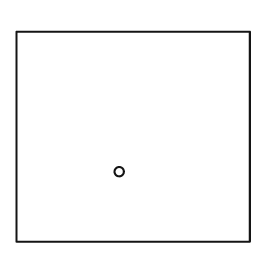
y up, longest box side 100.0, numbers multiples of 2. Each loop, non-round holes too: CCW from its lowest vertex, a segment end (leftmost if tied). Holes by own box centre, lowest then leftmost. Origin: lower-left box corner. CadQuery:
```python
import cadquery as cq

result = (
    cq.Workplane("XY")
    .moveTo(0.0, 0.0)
    .lineTo(100.0, 0.0)
    .lineTo(100.0, 90.0)
    .lineTo(0.0, 90.0)
    .close()
    .moveTo(44.0, 30.0)
    .circle(2.0)
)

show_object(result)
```